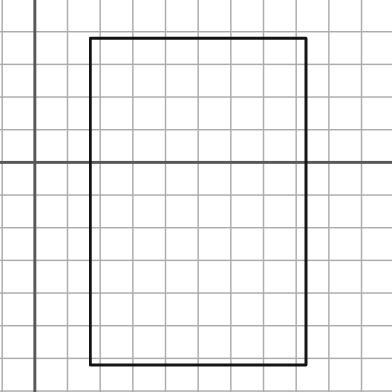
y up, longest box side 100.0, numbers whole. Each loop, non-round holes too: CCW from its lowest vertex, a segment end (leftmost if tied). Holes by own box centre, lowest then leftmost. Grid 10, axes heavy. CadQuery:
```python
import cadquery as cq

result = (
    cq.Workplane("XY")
    .moveTo(17.0, -62.0)
    .lineTo(83.0, -62.0)
    .lineTo(83.0, 38.0)
    .lineTo(17.0, 38.0)
    .close()
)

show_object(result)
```